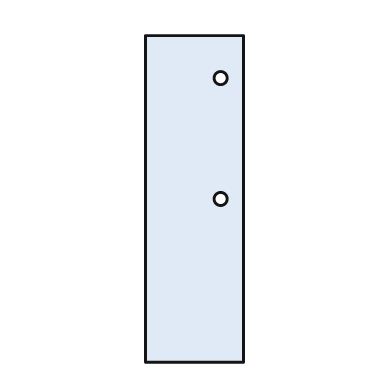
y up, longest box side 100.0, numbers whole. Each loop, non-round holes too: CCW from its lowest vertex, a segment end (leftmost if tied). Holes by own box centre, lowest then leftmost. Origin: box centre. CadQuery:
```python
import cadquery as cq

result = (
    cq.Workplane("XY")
    .moveTo(-15.0, -50.0)
    .lineTo(15.0, -50.0)
    .lineTo(15.0, 50.0)
    .lineTo(-15.0, 50.0)
    .close()
    .moveTo(8.0, 0.0)
    .circle(2.0)
    .moveTo(8.0, 37.0)
    .circle(2.0)
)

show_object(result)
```